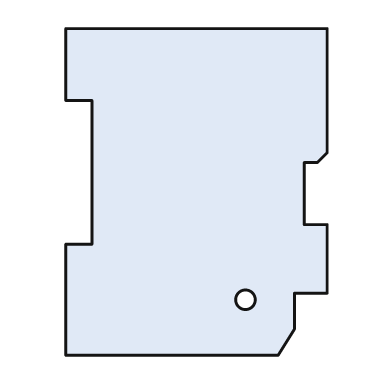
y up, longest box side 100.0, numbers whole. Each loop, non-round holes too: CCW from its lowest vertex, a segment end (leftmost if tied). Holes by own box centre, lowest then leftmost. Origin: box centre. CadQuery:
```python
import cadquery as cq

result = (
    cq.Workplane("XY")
    .moveTo(-40.0, -50.0)
    .lineTo(25.0, -50.0)
    .lineTo(30.0, -42.0)
    .lineTo(30.0, -31.0)
    .lineTo(40.0, -31.0)
    .lineTo(40.0, -10.0)
    .lineTo(33.0, -10.0)
    .lineTo(33.0, 9.0)
    .lineTo(37.0, 9.0)
    .lineTo(40.0, 12.0)
    .lineTo(40.0, 50.0)
    .lineTo(-40.0, 50.0)
    .lineTo(-40.0, 28.0)
    .lineTo(-32.0, 28.0)
    .lineTo(-32.0, -16.0)
    .lineTo(-40.0, -16.0)
    .close()
    .moveTo(15.0, -33.0)
    .circle(3.0)
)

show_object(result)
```